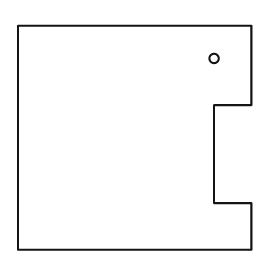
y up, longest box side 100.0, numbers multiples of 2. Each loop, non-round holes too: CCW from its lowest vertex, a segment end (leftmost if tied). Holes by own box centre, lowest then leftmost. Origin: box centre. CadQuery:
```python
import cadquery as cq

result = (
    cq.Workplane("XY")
    .moveTo(-50.0, -48.0)
    .lineTo(50.0, -48.0)
    .lineTo(50.0, -28.0)
    .lineTo(34.0, -28.0)
    .lineTo(34.0, 14.0)
    .lineTo(50.0, 14.0)
    .lineTo(50.0, 48.0)
    .lineTo(-50.0, 48.0)
    .close()
    .moveTo(34.0, 34.0)
    .circle(2.0)
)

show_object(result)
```